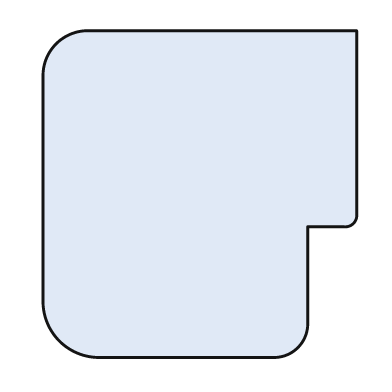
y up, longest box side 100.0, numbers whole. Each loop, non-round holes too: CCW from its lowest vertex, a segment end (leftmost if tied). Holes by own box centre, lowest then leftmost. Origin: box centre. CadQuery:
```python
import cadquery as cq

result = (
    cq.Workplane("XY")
    .moveTo(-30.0, -50.0)
    .lineTo(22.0, -50.0)
    .threePointArc((30.0, -47.0), (33.0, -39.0))
    .lineTo(33.0, -10.0)
    .lineTo(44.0, -10.0)
    .threePointArc((47.0, -9.0), (48.0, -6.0))
    .lineTo(48.0, 50.0)
    .lineTo(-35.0, 50.0)
    .threePointArc((-44.0, 46.0), (-48.0, 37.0))
    .lineTo(-48.0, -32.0)
    .threePointArc((-43.0, -45.0), (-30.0, -50.0))
    .close()
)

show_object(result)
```